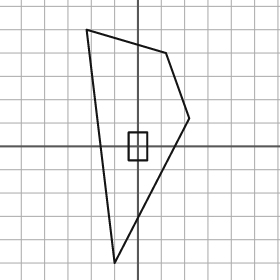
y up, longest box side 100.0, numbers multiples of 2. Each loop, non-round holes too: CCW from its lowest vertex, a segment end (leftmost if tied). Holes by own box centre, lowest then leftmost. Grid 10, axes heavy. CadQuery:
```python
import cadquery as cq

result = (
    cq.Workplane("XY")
    .moveTo(-10.0, -50.0)
    .lineTo(22.0, 12.0)
    .lineTo(12.0, 40.0)
    .lineTo(-22.0, 50.0)
    .close()
    .moveTo(-4.0, -6.0)
    .lineTo(4.0, -6.0)
    .lineTo(4.0, 6.0)
    .lineTo(-4.0, 6.0)
    .close()
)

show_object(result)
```